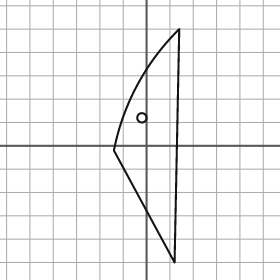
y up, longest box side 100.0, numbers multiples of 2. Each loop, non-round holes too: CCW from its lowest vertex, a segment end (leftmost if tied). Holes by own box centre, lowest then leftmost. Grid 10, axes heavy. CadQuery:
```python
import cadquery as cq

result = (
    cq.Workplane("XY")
    .moveTo(12.0, -50.0)
    .lineTo(14.0, 50.0)
    .threePointArc((-4.0, 26.0), (-14.0, -2.0))
    .close()
    .moveTo(-2.0, 12.0)
    .circle(2.0)
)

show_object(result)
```